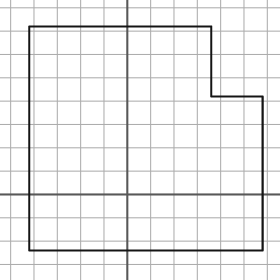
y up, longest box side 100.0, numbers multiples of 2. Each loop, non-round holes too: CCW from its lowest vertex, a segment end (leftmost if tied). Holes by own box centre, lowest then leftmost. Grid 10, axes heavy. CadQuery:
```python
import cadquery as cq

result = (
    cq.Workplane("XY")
    .moveTo(-42.0, -24.0)
    .lineTo(58.0, -24.0)
    .lineTo(58.0, 42.0)
    .lineTo(36.0, 42.0)
    .lineTo(36.0, 72.0)
    .lineTo(-42.0, 72.0)
    .close()
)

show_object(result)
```